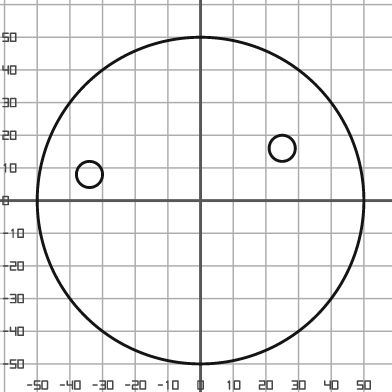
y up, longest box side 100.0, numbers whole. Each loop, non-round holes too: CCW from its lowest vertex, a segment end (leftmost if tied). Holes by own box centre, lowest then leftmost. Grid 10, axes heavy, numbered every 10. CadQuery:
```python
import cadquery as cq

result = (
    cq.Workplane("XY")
    .moveTo(0.0, 0.0)
    .circle(50.0)
    .moveTo(-34.0, 8.0)
    .circle(4.0)
    .moveTo(25.0, 16.0)
    .circle(4.0)
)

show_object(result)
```